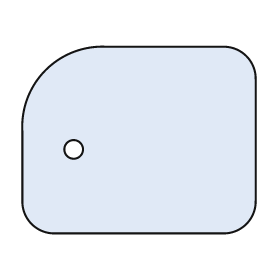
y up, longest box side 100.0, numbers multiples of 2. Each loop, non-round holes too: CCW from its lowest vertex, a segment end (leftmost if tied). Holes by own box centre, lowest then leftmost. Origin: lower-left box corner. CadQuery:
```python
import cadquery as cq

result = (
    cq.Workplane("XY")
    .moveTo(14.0, 0.0)
    .lineTo(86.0, 0.0)
    .threePointArc((96.0, 4.0), (100.0, 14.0))
    .lineTo(100.0, 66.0)
    .threePointArc((96.0, 76.0), (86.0, 80.0))
    .lineTo(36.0, 80.0)
    .threePointArc((10.0, 70.0), (0.0, 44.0))
    .lineTo(0.0, 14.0)
    .threePointArc((4.0, 4.0), (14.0, 0.0))
    .close()
    .moveTo(22.0, 36.0)
    .circle(4.0)
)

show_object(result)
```